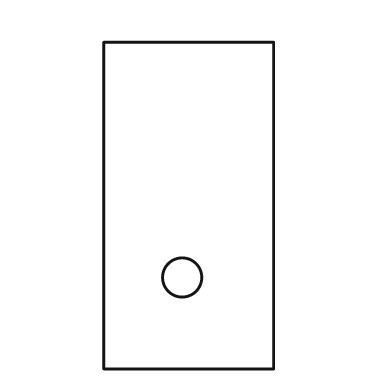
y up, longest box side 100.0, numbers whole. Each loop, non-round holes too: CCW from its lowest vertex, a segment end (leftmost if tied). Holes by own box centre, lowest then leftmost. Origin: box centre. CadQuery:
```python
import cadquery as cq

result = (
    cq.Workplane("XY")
    .moveTo(-26.0, -50.0)
    .lineTo(26.0, -50.0)
    .lineTo(26.0, 50.0)
    .lineTo(-26.0, 50.0)
    .close()
    .moveTo(-2.0, -22.0)
    .circle(6.0)
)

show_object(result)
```